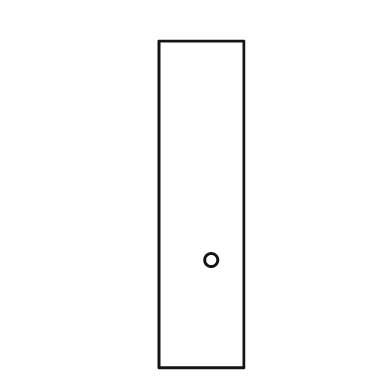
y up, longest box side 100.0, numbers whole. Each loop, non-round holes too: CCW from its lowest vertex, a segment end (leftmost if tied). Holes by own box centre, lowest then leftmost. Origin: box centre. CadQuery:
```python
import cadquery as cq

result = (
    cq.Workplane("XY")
    .moveTo(-13.0, -50.0)
    .lineTo(13.0, -50.0)
    .lineTo(13.0, 50.0)
    .lineTo(-13.0, 50.0)
    .close()
    .moveTo(3.0, -17.0)
    .circle(2.0)
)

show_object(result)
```